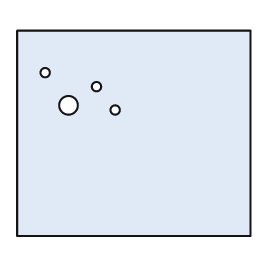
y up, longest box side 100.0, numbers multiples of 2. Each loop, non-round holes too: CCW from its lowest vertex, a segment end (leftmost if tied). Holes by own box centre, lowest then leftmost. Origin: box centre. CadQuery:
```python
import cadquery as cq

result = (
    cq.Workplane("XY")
    .moveTo(-50.0, -44.0)
    .lineTo(50.0, -44.0)
    .lineTo(50.0, 44.0)
    .lineTo(-50.0, 44.0)
    .close()
    .moveTo(-8.0, 10.0)
    .circle(2.0)
    .moveTo(-28.0, 12.0)
    .circle(4.0)
    .moveTo(-16.0, 20.0)
    .circle(2.0)
    .moveTo(-38.0, 26.0)
    .circle(2.0)
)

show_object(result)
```